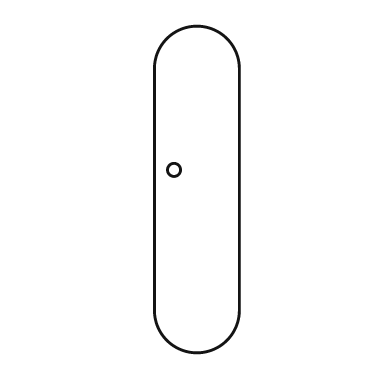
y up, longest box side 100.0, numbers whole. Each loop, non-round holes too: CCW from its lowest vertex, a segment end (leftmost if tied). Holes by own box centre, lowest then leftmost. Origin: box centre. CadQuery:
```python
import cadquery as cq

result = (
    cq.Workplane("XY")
    .moveTo(-13.0, -37.0)
    .threePointArc((0.0, -50.0), (13.0, -37.0))
    .lineTo(13.0, 37.0)
    .threePointArc((0.0, 50.0), (-13.0, 37.0))
    .close()
    .moveTo(-7.0, 6.0)
    .circle(2.0)
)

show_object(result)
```